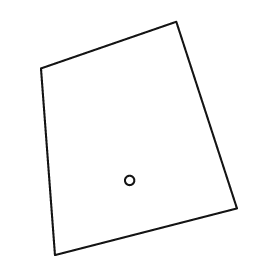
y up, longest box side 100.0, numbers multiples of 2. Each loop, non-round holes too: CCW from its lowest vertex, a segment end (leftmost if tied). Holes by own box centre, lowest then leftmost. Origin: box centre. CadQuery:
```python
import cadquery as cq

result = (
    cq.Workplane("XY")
    .moveTo(-36.0, -50.0)
    .lineTo(42.0, -30.0)
    .lineTo(16.0, 50.0)
    .lineTo(-42.0, 30.0)
    .close()
    .moveTo(-4.0, -18.0)
    .circle(2.0)
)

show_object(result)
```